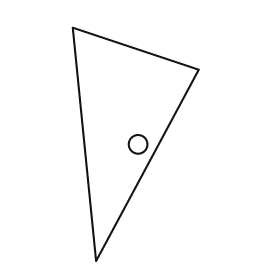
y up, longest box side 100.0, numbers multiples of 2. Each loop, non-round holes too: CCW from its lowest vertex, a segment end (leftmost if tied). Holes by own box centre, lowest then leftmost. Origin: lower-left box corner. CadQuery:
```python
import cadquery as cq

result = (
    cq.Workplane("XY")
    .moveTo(10.0, 0.0)
    .lineTo(54.0, 82.0)
    .lineTo(0.0, 100.0)
    .close()
    .moveTo(28.0, 50.0)
    .circle(4.0)
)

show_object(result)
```